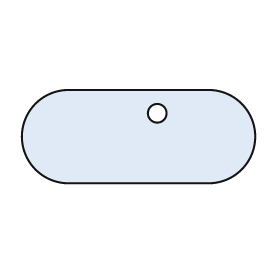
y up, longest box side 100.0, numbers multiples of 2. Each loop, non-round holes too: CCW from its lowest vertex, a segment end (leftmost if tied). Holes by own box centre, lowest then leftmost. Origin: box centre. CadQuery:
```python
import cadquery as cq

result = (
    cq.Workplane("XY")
    .moveTo(-30.0, -20.0)
    .lineTo(30.0, -20.0)
    .threePointArc((50.0, 0.0), (30.0, 20.0))
    .lineTo(-30.0, 20.0)
    .threePointArc((-50.0, 0.0), (-30.0, -20.0))
    .close()
    .moveTo(8.0, 10.0)
    .circle(4.0)
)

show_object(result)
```